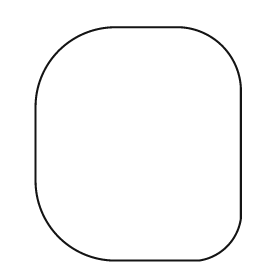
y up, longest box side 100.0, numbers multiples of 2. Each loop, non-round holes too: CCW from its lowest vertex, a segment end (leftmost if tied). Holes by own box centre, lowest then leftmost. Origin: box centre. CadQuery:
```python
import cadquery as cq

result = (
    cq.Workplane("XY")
    .moveTo(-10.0, -50.0)
    .lineTo(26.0, -50.0)
    .threePointArc((38.0, -44.0), (44.0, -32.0))
    .lineTo(44.0, 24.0)
    .threePointArc((36.0, 42.0), (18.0, 50.0))
    .lineTo(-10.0, 50.0)
    .threePointArc((-34.0, 40.0), (-44.0, 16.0))
    .lineTo(-44.0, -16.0)
    .threePointArc((-34.0, -40.0), (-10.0, -50.0))
    .close()
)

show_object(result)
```